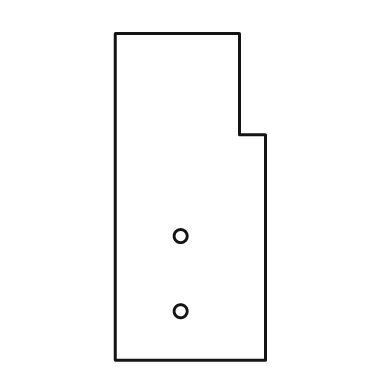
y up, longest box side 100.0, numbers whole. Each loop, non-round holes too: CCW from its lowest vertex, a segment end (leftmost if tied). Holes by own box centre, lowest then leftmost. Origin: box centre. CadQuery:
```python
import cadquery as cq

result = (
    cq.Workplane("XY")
    .moveTo(-23.0, -50.0)
    .lineTo(23.0, -50.0)
    .lineTo(23.0, 19.0)
    .lineTo(15.0, 19.0)
    .lineTo(15.0, 50.0)
    .lineTo(-23.0, 50.0)
    .close()
    .moveTo(-3.0, -35.0)
    .circle(2.0)
    .moveTo(-3.0, -12.0)
    .circle(2.0)
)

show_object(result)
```